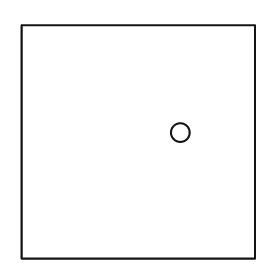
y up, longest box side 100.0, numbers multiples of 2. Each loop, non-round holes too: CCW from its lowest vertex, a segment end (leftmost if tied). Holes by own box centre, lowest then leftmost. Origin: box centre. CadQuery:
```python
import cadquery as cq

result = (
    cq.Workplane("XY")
    .moveTo(-50.0, -50.0)
    .lineTo(50.0, -50.0)
    .lineTo(50.0, 50.0)
    .lineTo(-50.0, 50.0)
    .close()
    .moveTo(18.0, 4.0)
    .circle(4.0)
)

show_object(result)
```